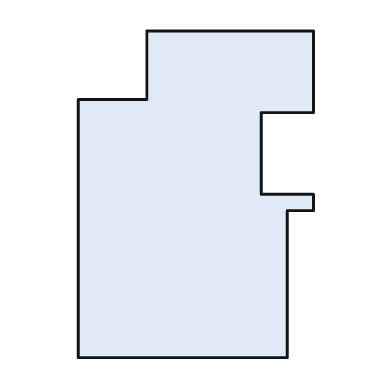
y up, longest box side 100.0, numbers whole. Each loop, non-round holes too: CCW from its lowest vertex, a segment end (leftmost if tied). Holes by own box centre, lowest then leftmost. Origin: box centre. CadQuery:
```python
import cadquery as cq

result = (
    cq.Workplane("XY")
    .moveTo(-36.0, -50.0)
    .lineTo(28.0, -50.0)
    .lineTo(28.0, -5.0)
    .lineTo(36.0, -5.0)
    .lineTo(36.0, 0.0)
    .lineTo(20.0, 0.0)
    .lineTo(20.0, 25.0)
    .lineTo(36.0, 25.0)
    .lineTo(36.0, 50.0)
    .lineTo(-15.0, 50.0)
    .lineTo(-15.0, 29.0)
    .lineTo(-36.0, 29.0)
    .close()
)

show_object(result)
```